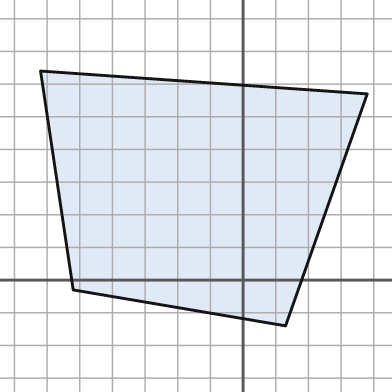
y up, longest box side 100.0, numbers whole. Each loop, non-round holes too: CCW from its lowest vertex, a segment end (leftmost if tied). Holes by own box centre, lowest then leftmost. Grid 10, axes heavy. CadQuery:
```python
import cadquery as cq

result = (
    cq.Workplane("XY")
    .moveTo(13.0, -14.0)
    .lineTo(38.0, 57.0)
    .lineTo(-62.0, 64.0)
    .lineTo(-52.0, -3.0)
    .close()
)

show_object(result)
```